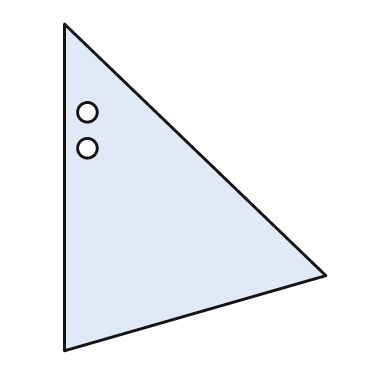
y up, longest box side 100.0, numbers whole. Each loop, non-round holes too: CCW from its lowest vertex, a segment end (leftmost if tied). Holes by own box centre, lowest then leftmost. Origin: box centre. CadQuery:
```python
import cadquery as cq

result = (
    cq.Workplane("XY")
    .moveTo(-40.0, -50.0)
    .lineTo(40.0, -27.0)
    .lineTo(-40.0, 50.0)
    .close()
    .moveTo(-33.0, 12.0)
    .circle(3.0)
    .moveTo(-33.0, 23.0)
    .circle(3.0)
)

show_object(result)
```